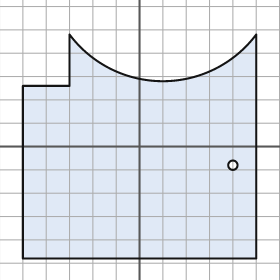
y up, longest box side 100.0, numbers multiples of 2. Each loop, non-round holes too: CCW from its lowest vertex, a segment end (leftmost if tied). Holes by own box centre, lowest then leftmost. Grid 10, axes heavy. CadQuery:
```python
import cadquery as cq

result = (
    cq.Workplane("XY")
    .moveTo(-50.0, -48.0)
    .lineTo(50.0, -48.0)
    .lineTo(50.0, 48.0)
    .threePointArc((10.0, 28.0), (-30.0, 48.0))
    .lineTo(-30.0, 26.0)
    .lineTo(-50.0, 26.0)
    .close()
    .moveTo(40.0, -8.0)
    .circle(2.0)
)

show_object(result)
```